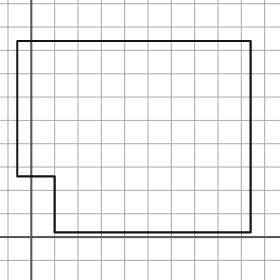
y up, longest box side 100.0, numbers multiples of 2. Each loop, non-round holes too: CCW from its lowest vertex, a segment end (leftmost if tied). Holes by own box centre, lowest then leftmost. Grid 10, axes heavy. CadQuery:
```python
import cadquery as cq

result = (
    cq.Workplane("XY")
    .moveTo(10.0, 2.0)
    .lineTo(94.0, 2.0)
    .lineTo(94.0, 84.0)
    .lineTo(-6.0, 84.0)
    .lineTo(-6.0, 26.0)
    .lineTo(10.0, 26.0)
    .close()
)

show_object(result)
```